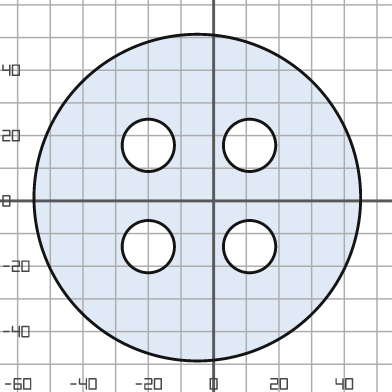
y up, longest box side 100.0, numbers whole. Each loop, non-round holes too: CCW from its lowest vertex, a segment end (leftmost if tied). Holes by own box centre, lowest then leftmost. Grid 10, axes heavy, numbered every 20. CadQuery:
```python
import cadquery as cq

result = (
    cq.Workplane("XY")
    .moveTo(-5.0, 1.0)
    .circle(50.0)
    .moveTo(-20.0, -14.0)
    .circle(8.0)
    .moveTo(11.0, -14.0)
    .circle(8.0)
    .moveTo(-20.0, 17.0)
    .circle(8.0)
    .moveTo(11.0, 17.0)
    .circle(8.0)
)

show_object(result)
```